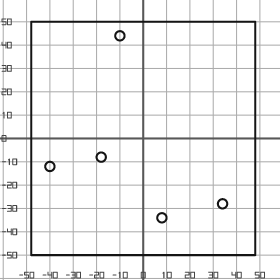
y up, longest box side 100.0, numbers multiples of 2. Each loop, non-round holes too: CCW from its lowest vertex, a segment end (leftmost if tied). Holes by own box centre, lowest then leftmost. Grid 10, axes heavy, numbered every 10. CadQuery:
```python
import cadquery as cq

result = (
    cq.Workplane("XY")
    .moveTo(-48.0, -50.0)
    .lineTo(48.0, -50.0)
    .lineTo(48.0, 50.0)
    .lineTo(-48.0, 50.0)
    .close()
    .moveTo(8.0, -34.0)
    .circle(2.0)
    .moveTo(34.0, -28.0)
    .circle(2.0)
    .moveTo(-40.0, -12.0)
    .circle(2.0)
    .moveTo(-18.0, -8.0)
    .circle(2.0)
    .moveTo(-10.0, 44.0)
    .circle(2.0)
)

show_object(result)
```